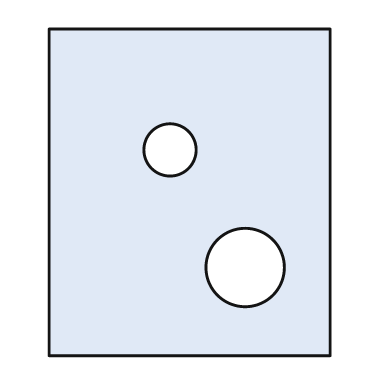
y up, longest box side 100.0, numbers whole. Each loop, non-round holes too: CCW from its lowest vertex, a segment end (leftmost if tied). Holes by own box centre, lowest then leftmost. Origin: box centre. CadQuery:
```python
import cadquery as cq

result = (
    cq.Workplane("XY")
    .moveTo(-43.0, -50.0)
    .lineTo(43.0, -50.0)
    .lineTo(43.0, 50.0)
    .lineTo(-43.0, 50.0)
    .close()
    .moveTo(17.0, -23.0)
    .circle(12.0)
    .moveTo(-6.0, 13.0)
    .circle(8.0)
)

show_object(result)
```